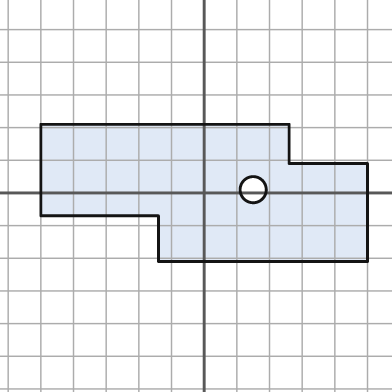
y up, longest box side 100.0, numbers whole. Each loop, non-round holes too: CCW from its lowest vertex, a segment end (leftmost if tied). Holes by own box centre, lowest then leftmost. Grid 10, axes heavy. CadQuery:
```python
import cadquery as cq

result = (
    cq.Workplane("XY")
    .moveTo(-14.0, -21.0)
    .lineTo(50.0, -21.0)
    .lineTo(50.0, 9.0)
    .lineTo(26.0, 9.0)
    .lineTo(26.0, 21.0)
    .lineTo(-50.0, 21.0)
    .lineTo(-50.0, -7.0)
    .lineTo(-14.0, -7.0)
    .close()
    .moveTo(15.0, 1.0)
    .circle(4.0)
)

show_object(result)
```